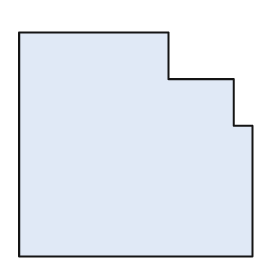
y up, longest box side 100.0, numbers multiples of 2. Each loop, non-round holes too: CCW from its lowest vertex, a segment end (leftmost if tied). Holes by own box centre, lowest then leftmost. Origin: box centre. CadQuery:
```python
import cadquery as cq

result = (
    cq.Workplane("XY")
    .moveTo(-50.0, -48.0)
    .lineTo(50.0, -48.0)
    .lineTo(50.0, 8.0)
    .lineTo(42.0, 8.0)
    .lineTo(42.0, 28.0)
    .lineTo(14.0, 28.0)
    .lineTo(14.0, 48.0)
    .lineTo(-50.0, 48.0)
    .close()
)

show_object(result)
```